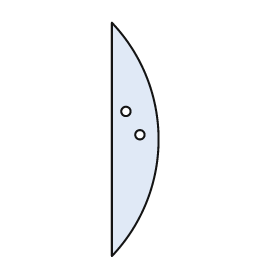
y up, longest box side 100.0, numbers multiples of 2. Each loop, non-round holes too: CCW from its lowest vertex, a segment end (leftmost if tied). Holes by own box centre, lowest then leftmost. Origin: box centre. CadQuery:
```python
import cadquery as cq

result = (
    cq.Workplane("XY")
    .moveTo(-10.0, -50.0)
    .threePointArc((10.0, 0.0), (-10.0, 50.0))
    .close()
    .moveTo(2.0, 2.0)
    .circle(2.0)
    .moveTo(-4.0, 12.0)
    .circle(2.0)
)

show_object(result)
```